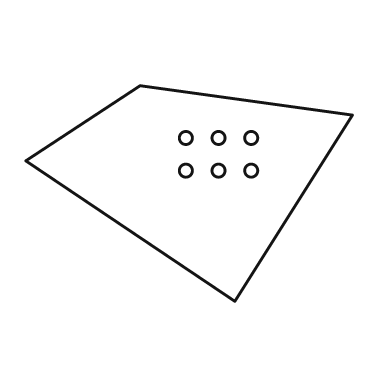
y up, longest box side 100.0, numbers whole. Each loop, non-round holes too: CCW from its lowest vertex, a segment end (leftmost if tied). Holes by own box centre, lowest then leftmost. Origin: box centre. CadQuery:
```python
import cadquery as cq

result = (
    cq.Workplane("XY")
    .moveTo(14.0, -33.0)
    .lineTo(50.0, 24.0)
    .lineTo(-15.0, 33.0)
    .lineTo(-50.0, 10.0)
    .close()
    .moveTo(-1.0, 7.0)
    .circle(2.0)
    .moveTo(9.0, 7.0)
    .circle(2.0)
    .moveTo(19.0, 7.0)
    .circle(2.0)
    .moveTo(-1.0, 17.0)
    .circle(2.0)
    .moveTo(9.0, 17.0)
    .circle(2.0)
    .moveTo(19.0, 17.0)
    .circle(2.0)
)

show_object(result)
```